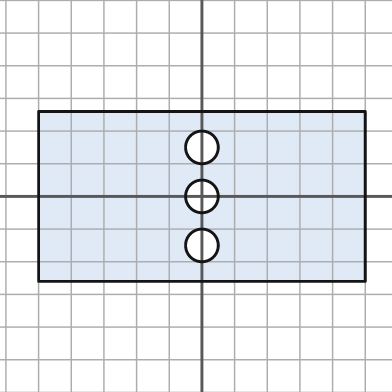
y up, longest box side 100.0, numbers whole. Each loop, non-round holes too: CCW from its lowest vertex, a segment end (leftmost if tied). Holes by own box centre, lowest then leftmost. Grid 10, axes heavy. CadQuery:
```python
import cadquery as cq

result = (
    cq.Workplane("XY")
    .moveTo(-50.0, -26.0)
    .lineTo(50.0, -26.0)
    .lineTo(50.0, 26.0)
    .lineTo(-50.0, 26.0)
    .close()
    .moveTo(0.0, -15.0)
    .circle(5.0)
    .moveTo(0.0, 0.0)
    .circle(5.0)
    .moveTo(0.0, 15.0)
    .circle(5.0)
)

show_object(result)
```